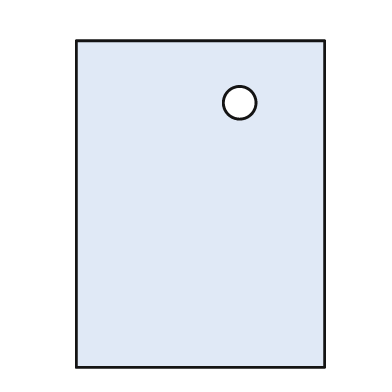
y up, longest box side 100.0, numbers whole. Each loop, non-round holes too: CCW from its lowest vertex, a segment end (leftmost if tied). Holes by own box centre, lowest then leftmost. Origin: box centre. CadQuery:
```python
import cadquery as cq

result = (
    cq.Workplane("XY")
    .moveTo(-38.0, -50.0)
    .lineTo(38.0, -50.0)
    .lineTo(38.0, 50.0)
    .lineTo(-38.0, 50.0)
    .close()
    .moveTo(12.0, 31.0)
    .circle(5.0)
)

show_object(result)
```